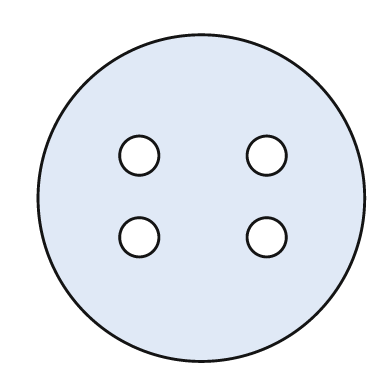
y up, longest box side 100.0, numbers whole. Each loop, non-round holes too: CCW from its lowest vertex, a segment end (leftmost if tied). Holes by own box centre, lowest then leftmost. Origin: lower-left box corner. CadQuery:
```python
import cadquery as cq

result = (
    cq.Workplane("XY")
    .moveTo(50.0, 50.0)
    .circle(50.0)
    .moveTo(31.0, 38.0)
    .circle(6.0)
    .moveTo(70.0, 38.0)
    .circle(6.0)
    .moveTo(31.0, 63.0)
    .circle(6.0)
    .moveTo(70.0, 63.0)
    .circle(6.0)
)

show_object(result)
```